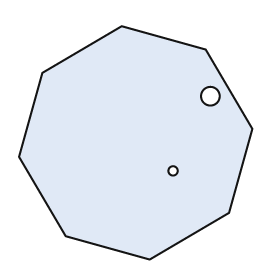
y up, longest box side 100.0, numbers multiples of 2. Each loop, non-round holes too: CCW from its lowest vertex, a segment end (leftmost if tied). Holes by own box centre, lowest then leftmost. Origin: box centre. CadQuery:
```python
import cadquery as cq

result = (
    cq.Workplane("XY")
    .moveTo(6.0, -50.0)
    .lineTo(40.0, -30.0)
    .lineTo(50.0, 6.0)
    .lineTo(30.0, 40.0)
    .lineTo(-6.0, 50.0)
    .lineTo(-40.0, 30.0)
    .lineTo(-50.0, -6.0)
    .lineTo(-30.0, -40.0)
    .close()
    .moveTo(16.0, -12.0)
    .circle(2.0)
    .moveTo(32.0, 20.0)
    .circle(4.0)
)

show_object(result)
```